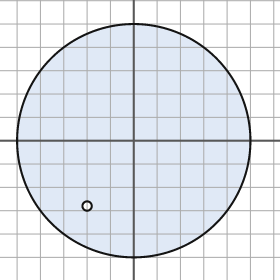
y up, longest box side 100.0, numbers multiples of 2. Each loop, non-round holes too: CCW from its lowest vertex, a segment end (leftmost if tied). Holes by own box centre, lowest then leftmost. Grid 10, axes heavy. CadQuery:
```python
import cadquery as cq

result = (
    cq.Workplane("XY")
    .moveTo(0.0, 0.0)
    .circle(50.0)
    .moveTo(-20.0, -28.0)
    .circle(2.0)
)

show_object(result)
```